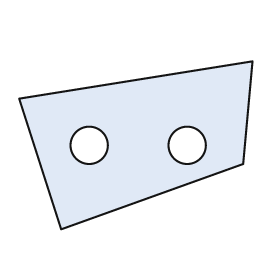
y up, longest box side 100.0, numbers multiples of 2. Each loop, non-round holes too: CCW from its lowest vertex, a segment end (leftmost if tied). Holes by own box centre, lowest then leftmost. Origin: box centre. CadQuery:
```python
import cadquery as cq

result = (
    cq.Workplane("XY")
    .moveTo(-32.0, -36.0)
    .lineTo(46.0, -8.0)
    .lineTo(50.0, 36.0)
    .lineTo(-50.0, 20.0)
    .close()
    .moveTo(-20.0, 0.0)
    .circle(8.0)
    .moveTo(22.0, 0.0)
    .circle(8.0)
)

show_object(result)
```